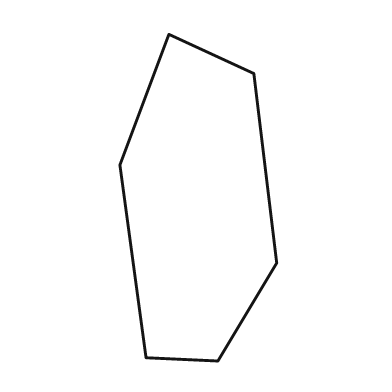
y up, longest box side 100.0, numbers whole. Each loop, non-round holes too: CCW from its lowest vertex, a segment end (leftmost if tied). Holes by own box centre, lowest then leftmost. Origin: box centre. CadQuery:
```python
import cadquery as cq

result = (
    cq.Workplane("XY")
    .moveTo(6.0, -50.0)
    .lineTo(24.0, -20.0)
    .lineTo(17.0, 38.0)
    .lineTo(-9.0, 50.0)
    .lineTo(-24.0, 10.0)
    .lineTo(-16.0, -49.0)
    .close()
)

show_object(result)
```